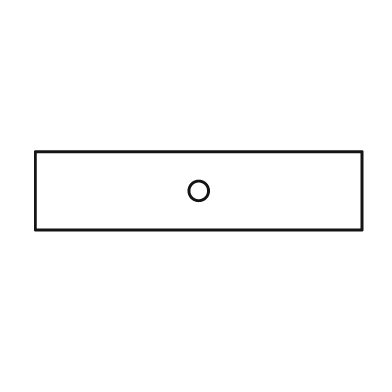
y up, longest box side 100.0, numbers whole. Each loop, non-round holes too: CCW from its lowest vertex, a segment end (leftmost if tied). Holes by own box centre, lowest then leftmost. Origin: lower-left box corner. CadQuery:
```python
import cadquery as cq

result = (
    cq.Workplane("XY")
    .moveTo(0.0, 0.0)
    .lineTo(100.0, 0.0)
    .lineTo(100.0, 24.0)
    .lineTo(0.0, 24.0)
    .close()
    .moveTo(50.0, 12.0)
    .circle(3.0)
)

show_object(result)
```